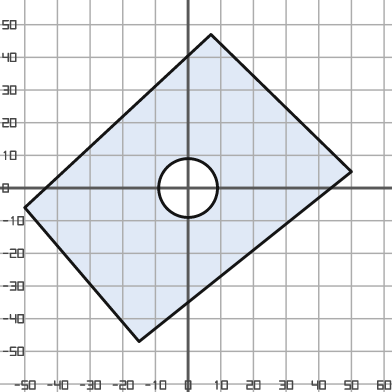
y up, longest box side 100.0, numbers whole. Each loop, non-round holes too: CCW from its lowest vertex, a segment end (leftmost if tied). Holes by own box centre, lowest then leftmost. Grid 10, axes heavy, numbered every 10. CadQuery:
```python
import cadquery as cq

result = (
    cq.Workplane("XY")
    .moveTo(-15.0, -47.0)
    .lineTo(50.0, 5.0)
    .lineTo(7.0, 47.0)
    .lineTo(-50.0, -6.0)
    .close()
    .moveTo(0.0, 0.0)
    .circle(9.0)
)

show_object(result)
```